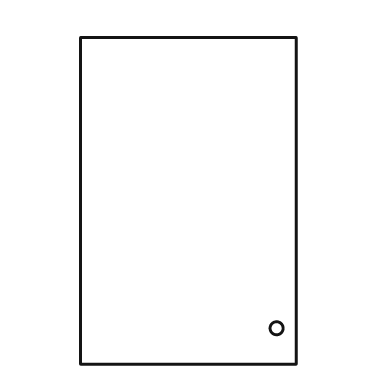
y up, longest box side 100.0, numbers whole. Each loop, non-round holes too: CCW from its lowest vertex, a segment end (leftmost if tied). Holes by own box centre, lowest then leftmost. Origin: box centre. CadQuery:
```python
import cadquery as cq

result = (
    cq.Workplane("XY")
    .moveTo(-33.0, -50.0)
    .lineTo(33.0, -50.0)
    .lineTo(33.0, 50.0)
    .lineTo(-33.0, 50.0)
    .close()
    .moveTo(27.0, -39.0)
    .circle(2.0)
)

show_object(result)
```